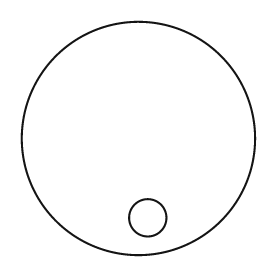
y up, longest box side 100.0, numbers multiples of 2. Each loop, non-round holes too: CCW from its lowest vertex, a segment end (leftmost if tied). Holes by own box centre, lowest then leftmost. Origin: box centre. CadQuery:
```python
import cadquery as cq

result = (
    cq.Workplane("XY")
    .moveTo(0.0, 0.0)
    .circle(50.0)
    .moveTo(4.0, -34.0)
    .circle(8.0)
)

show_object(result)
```